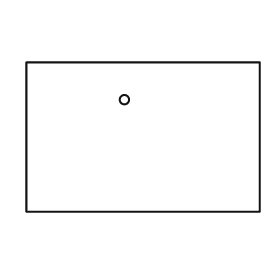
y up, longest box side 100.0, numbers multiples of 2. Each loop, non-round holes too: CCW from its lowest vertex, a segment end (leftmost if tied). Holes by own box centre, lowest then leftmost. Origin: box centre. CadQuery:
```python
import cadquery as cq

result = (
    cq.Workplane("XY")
    .moveTo(-50.0, -32.0)
    .lineTo(50.0, -32.0)
    .lineTo(50.0, 32.0)
    .lineTo(-50.0, 32.0)
    .close()
    .moveTo(-8.0, 16.0)
    .circle(2.0)
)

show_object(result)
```